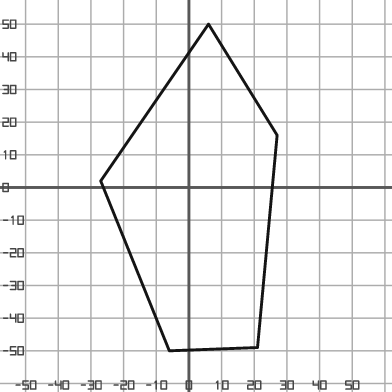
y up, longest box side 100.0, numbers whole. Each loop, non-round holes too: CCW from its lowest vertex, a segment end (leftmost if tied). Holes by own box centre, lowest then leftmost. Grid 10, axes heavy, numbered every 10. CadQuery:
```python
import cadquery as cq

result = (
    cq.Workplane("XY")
    .moveTo(-6.0, -50.0)
    .lineTo(21.0, -49.0)
    .lineTo(27.0, 16.0)
    .lineTo(6.0, 50.0)
    .lineTo(-27.0, 2.0)
    .close()
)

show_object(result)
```